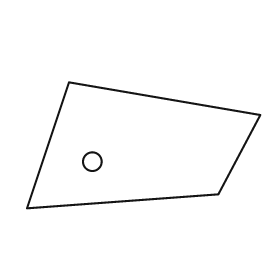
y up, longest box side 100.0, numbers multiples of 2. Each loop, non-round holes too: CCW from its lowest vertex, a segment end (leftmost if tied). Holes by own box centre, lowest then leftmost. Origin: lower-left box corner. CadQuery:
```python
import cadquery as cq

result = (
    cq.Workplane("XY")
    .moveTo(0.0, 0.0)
    .lineTo(82.0, 6.0)
    .lineTo(100.0, 40.0)
    .lineTo(18.0, 54.0)
    .close()
    .moveTo(28.0, 20.0)
    .circle(4.0)
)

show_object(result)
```